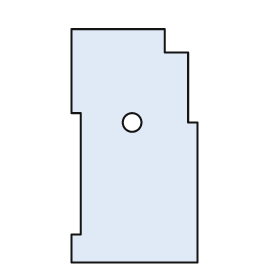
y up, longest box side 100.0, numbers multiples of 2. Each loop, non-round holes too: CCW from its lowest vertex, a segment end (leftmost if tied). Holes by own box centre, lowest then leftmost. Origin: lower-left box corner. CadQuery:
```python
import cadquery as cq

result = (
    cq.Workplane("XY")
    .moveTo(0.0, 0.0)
    .lineTo(54.0, 0.0)
    .lineTo(54.0, 60.0)
    .lineTo(50.0, 60.0)
    .lineTo(50.0, 90.0)
    .lineTo(40.0, 90.0)
    .lineTo(40.0, 100.0)
    .lineTo(0.0, 100.0)
    .lineTo(0.0, 64.0)
    .lineTo(4.0, 64.0)
    .lineTo(4.0, 12.0)
    .lineTo(0.0, 12.0)
    .close()
    .moveTo(26.0, 60.0)
    .circle(4.0)
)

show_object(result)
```